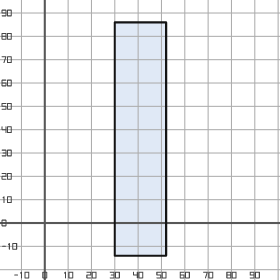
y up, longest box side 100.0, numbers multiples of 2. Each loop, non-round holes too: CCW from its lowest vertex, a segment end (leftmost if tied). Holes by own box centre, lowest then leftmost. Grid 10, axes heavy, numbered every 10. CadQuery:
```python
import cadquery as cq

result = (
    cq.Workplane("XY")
    .moveTo(30.0, -14.0)
    .lineTo(52.0, -14.0)
    .lineTo(52.0, 86.0)
    .lineTo(30.0, 86.0)
    .close()
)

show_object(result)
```